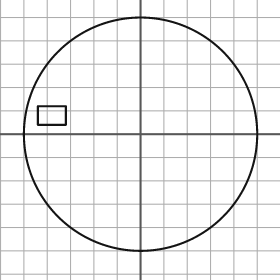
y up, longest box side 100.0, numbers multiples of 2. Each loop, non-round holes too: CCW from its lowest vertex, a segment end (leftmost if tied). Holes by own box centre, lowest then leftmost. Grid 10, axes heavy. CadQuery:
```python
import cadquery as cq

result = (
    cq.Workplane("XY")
    .moveTo(0.0, 0.0)
    .circle(50.0)
    .moveTo(-44.0, 4.0)
    .lineTo(-32.0, 4.0)
    .lineTo(-32.0, 12.0)
    .lineTo(-44.0, 12.0)
    .close()
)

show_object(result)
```